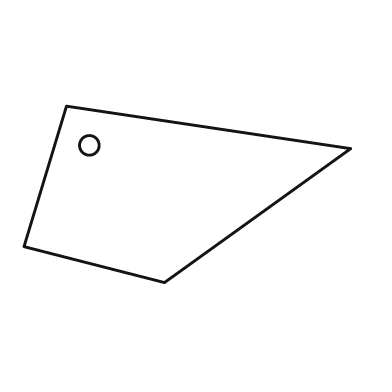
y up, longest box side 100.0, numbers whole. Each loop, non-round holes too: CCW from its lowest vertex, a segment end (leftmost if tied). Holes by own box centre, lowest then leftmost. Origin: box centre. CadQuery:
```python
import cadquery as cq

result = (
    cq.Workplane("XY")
    .moveTo(-7.0, -27.0)
    .lineTo(50.0, 14.0)
    .lineTo(-37.0, 27.0)
    .lineTo(-50.0, -16.0)
    .close()
    .moveTo(-30.0, 15.0)
    .circle(3.0)
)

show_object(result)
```